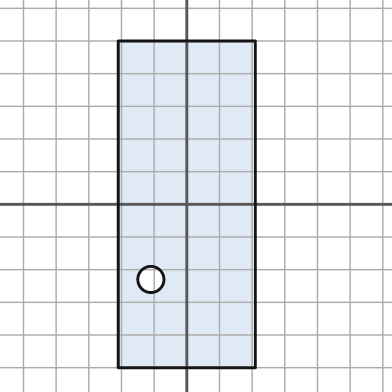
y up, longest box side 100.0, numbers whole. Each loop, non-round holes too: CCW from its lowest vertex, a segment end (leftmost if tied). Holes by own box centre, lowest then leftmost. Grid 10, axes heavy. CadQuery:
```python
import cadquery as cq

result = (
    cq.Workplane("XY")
    .moveTo(-21.0, -50.0)
    .lineTo(21.0, -50.0)
    .lineTo(21.0, 50.0)
    .lineTo(-21.0, 50.0)
    .close()
    .moveTo(-11.0, -23.0)
    .circle(4.0)
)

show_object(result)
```